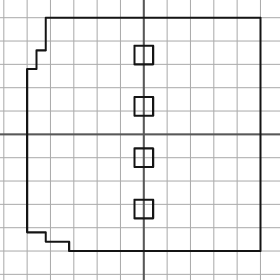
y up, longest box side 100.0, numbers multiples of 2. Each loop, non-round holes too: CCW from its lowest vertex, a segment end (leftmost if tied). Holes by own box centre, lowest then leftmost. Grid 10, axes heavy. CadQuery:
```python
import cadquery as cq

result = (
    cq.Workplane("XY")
    .moveTo(-32.0, -50.0)
    .lineTo(50.0, -50.0)
    .lineTo(50.0, 50.0)
    .lineTo(-42.0, 50.0)
    .lineTo(-42.0, 36.0)
    .lineTo(-46.0, 36.0)
    .lineTo(-46.0, 28.0)
    .lineTo(-50.0, 28.0)
    .lineTo(-50.0, -42.0)
    .lineTo(-42.0, -42.0)
    .lineTo(-42.0, -46.0)
    .lineTo(-32.0, -46.0)
    .close()
    .moveTo(-4.0, -36.0)
    .lineTo(4.0, -36.0)
    .lineTo(4.0, -28.0)
    .lineTo(-4.0, -28.0)
    .close()
    .moveTo(-4.0, -14.0)
    .lineTo(4.0, -14.0)
    .lineTo(4.0, -6.0)
    .lineTo(-4.0, -6.0)
    .close()
    .moveTo(-4.0, 8.0)
    .lineTo(4.0, 8.0)
    .lineTo(4.0, 16.0)
    .lineTo(-4.0, 16.0)
    .close()
    .moveTo(-4.0, 30.0)
    .lineTo(4.0, 30.0)
    .lineTo(4.0, 38.0)
    .lineTo(-4.0, 38.0)
    .close()
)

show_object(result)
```